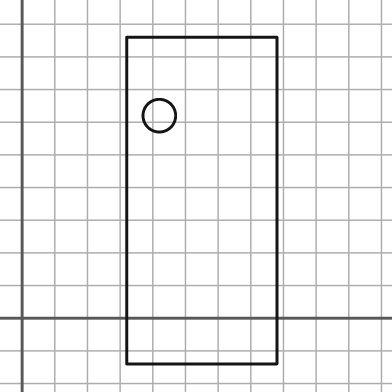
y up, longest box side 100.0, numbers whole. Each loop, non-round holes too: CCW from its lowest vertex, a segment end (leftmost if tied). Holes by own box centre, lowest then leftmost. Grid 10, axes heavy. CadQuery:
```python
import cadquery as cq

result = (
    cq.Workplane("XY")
    .moveTo(32.0, -14.0)
    .lineTo(78.0, -14.0)
    .lineTo(78.0, 86.0)
    .lineTo(32.0, 86.0)
    .close()
    .moveTo(42.0, 62.0)
    .circle(5.0)
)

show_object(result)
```